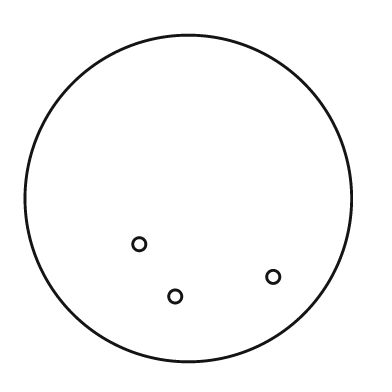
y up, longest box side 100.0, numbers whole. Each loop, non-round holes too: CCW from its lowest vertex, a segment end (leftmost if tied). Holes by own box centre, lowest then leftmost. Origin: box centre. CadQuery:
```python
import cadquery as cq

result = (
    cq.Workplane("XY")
    .moveTo(0.0, 0.0)
    .circle(50.0)
    .moveTo(-4.0, -30.0)
    .circle(2.0)
    .moveTo(26.0, -24.0)
    .circle(2.0)
    .moveTo(-15.0, -14.0)
    .circle(2.0)
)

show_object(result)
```